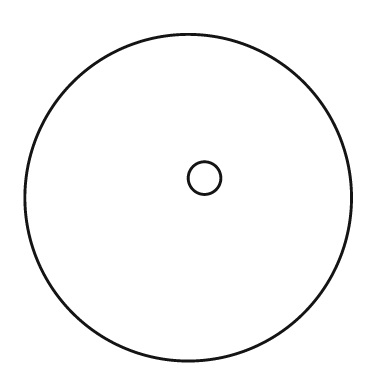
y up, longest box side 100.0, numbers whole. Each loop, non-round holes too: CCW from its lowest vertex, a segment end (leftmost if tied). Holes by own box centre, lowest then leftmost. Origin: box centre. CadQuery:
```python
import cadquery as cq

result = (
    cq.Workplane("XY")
    .moveTo(0.0, 0.0)
    .circle(50.0)
    .moveTo(5.0, 6.0)
    .circle(5.0)
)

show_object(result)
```